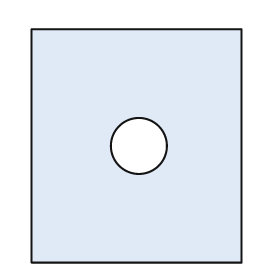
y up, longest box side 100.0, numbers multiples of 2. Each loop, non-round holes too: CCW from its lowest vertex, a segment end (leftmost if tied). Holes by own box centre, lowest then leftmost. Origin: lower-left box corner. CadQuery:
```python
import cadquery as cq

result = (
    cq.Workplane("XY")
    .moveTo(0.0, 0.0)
    .lineTo(90.0, 0.0)
    .lineTo(90.0, 100.0)
    .lineTo(0.0, 100.0)
    .close()
    .moveTo(46.0, 50.0)
    .circle(12.0)
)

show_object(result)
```